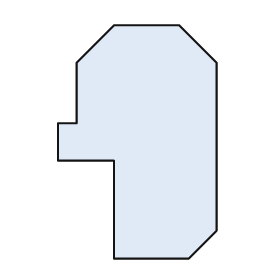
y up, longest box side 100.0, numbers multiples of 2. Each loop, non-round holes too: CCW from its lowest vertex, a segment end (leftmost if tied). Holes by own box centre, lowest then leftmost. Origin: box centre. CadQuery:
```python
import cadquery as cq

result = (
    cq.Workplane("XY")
    .moveTo(-10.0, -50.0)
    .lineTo(22.0, -50.0)
    .lineTo(34.0, -38.0)
    .lineTo(34.0, 34.0)
    .lineTo(18.0, 50.0)
    .lineTo(-10.0, 50.0)
    .lineTo(-26.0, 34.0)
    .lineTo(-26.0, 8.0)
    .lineTo(-34.0, 8.0)
    .lineTo(-34.0, -8.0)
    .lineTo(-10.0, -8.0)
    .close()
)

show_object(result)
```